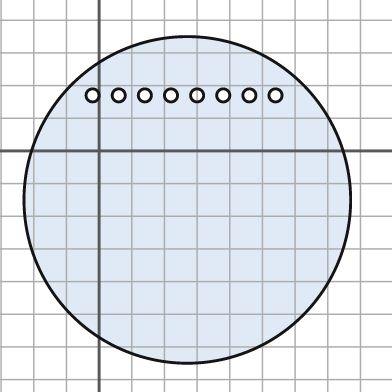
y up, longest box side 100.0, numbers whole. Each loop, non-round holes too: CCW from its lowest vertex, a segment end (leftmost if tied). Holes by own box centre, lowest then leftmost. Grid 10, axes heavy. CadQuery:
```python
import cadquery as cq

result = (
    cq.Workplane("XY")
    .moveTo(27.0, -15.0)
    .circle(50.0)
    .moveTo(-2.0, 17.0)
    .circle(2.0)
    .moveTo(6.0, 17.0)
    .circle(2.0)
    .moveTo(14.0, 17.0)
    .circle(2.0)
    .moveTo(22.0, 17.0)
    .circle(2.0)
    .moveTo(30.0, 17.0)
    .circle(2.0)
    .moveTo(38.0, 17.0)
    .circle(2.0)
    .moveTo(46.0, 17.0)
    .circle(2.0)
    .moveTo(54.0, 17.0)
    .circle(2.0)
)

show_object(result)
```